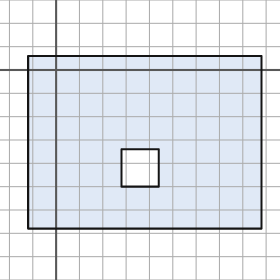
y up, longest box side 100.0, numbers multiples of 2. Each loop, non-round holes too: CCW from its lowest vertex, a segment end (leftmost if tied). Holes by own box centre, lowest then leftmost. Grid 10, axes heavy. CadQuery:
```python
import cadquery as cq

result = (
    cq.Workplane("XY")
    .moveTo(-12.0, -68.0)
    .lineTo(88.0, -68.0)
    .lineTo(88.0, 6.0)
    .lineTo(-12.0, 6.0)
    .close()
    .moveTo(28.0, -50.0)
    .lineTo(44.0, -50.0)
    .lineTo(44.0, -34.0)
    .lineTo(28.0, -34.0)
    .close()
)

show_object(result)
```